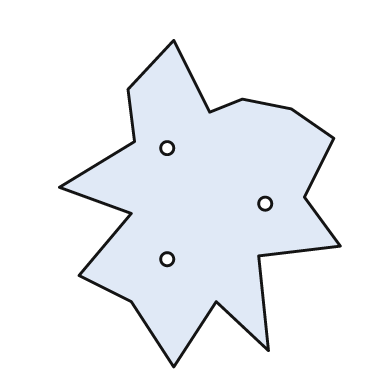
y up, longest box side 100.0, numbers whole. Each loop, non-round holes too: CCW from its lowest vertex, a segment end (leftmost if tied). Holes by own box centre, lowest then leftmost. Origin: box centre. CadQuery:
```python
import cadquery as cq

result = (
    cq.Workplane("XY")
    .moveTo(-8.0, -50.0)
    .lineTo(5.0, -30.0)
    .lineTo(21.0, -45.0)
    .lineTo(18.0, -16.0)
    .lineTo(43.0, -13.0)
    .lineTo(32.0, 2.0)
    .lineTo(41.0, 20.0)
    .lineTo(28.0, 29.0)
    .lineTo(13.0, 32.0)
    .lineTo(3.0, 28.0)
    .lineTo(-8.0, 50.0)
    .lineTo(-22.0, 35.0)
    .lineTo(-20.0, 19.0)
    .lineTo(-43.0, 5.0)
    .lineTo(-21.0, -3.0)
    .lineTo(-37.0, -22.0)
    .lineTo(-21.0, -30.0)
    .close()
    .moveTo(-10.0, -17.0)
    .circle(2.0)
    .moveTo(20.0, 0.0)
    .circle(2.0)
    .moveTo(-10.0, 17.0)
    .circle(2.0)
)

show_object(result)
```